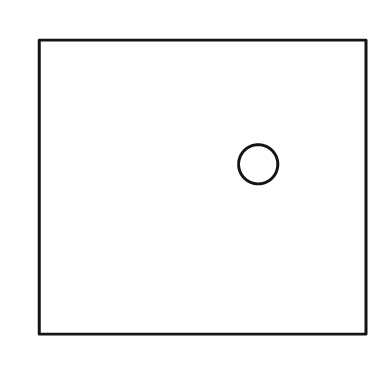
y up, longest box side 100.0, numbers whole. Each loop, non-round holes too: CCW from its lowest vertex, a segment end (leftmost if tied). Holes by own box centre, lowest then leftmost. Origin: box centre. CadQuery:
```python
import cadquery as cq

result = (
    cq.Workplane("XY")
    .moveTo(-50.0, -45.0)
    .lineTo(50.0, -45.0)
    .lineTo(50.0, 45.0)
    .lineTo(-50.0, 45.0)
    .close()
    .moveTo(17.0, 7.0)
    .circle(6.0)
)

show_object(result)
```